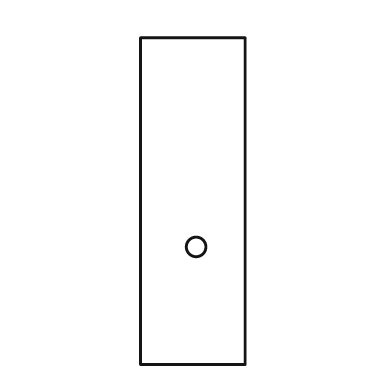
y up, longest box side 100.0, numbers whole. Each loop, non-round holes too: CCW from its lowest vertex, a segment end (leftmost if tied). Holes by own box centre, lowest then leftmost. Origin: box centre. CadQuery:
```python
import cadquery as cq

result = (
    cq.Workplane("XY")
    .moveTo(-16.0, -50.0)
    .lineTo(16.0, -50.0)
    .lineTo(16.0, 50.0)
    .lineTo(-16.0, 50.0)
    .close()
    .moveTo(1.0, -14.0)
    .circle(3.0)
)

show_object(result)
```